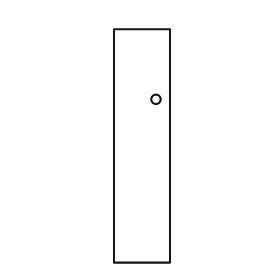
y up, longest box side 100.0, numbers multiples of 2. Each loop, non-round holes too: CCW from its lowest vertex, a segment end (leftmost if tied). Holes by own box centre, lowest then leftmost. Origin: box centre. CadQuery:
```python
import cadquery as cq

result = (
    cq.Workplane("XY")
    .moveTo(-12.0, -50.0)
    .lineTo(12.0, -50.0)
    .lineTo(12.0, 50.0)
    .lineTo(-12.0, 50.0)
    .close()
    .moveTo(6.0, 20.0)
    .circle(2.0)
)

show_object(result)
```